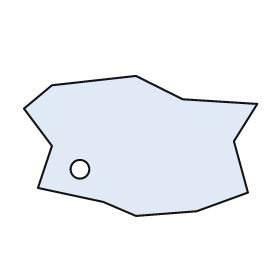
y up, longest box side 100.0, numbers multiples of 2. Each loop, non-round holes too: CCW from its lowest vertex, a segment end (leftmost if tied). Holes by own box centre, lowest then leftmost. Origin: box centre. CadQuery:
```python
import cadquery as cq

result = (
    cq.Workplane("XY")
    .moveTo(-2.0, -30.0)
    .lineTo(24.0, -28.0)
    .lineTo(46.0, -20.0)
    .lineTo(40.0, 2.0)
    .lineTo(50.0, 18.0)
    .lineTo(18.0, 20.0)
    .lineTo(-2.0, 30.0)
    .lineTo(-38.0, 26.0)
    .lineTo(-50.0, 16.0)
    .lineTo(-38.0, 0.0)
    .lineTo(-44.0, -18.0)
    .lineTo(-16.0, -24.0)
    .close()
    .moveTo(-26.0, -10.0)
    .circle(4.0)
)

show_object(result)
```